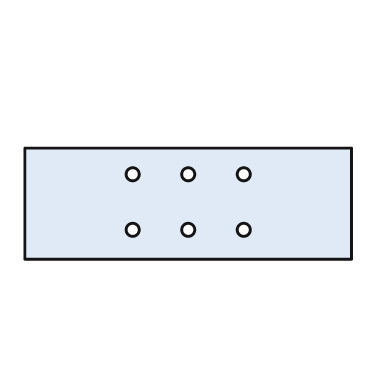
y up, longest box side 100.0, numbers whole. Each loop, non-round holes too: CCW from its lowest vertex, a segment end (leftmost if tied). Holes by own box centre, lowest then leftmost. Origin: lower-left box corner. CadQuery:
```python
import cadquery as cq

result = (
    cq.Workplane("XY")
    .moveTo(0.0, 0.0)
    .lineTo(100.0, 0.0)
    .lineTo(100.0, 34.0)
    .lineTo(0.0, 34.0)
    .close()
    .moveTo(33.0, 9.0)
    .circle(2.0)
    .moveTo(50.0, 9.0)
    .circle(2.0)
    .moveTo(67.0, 9.0)
    .circle(2.0)
    .moveTo(33.0, 26.0)
    .circle(2.0)
    .moveTo(50.0, 26.0)
    .circle(2.0)
    .moveTo(67.0, 26.0)
    .circle(2.0)
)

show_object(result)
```